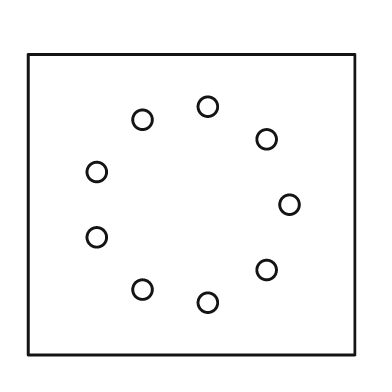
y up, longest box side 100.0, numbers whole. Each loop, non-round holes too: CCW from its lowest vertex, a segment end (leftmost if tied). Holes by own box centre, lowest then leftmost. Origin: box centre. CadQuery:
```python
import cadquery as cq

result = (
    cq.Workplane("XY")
    .moveTo(-50.0, -46.0)
    .lineTo(50.0, -46.0)
    .lineTo(50.0, 46.0)
    .lineTo(-50.0, 46.0)
    .close()
    .moveTo(5.0, -30.0)
    .circle(3.0)
    .moveTo(-15.0, -26.0)
    .circle(3.0)
    .moveTo(23.0, -20.0)
    .circle(3.0)
    .moveTo(-29.0, -10.0)
    .circle(3.0)
    .moveTo(30.0, 0.0)
    .circle(3.0)
    .moveTo(-29.0, 10.0)
    .circle(3.0)
    .moveTo(23.0, 20.0)
    .circle(3.0)
    .moveTo(-15.0, 26.0)
    .circle(3.0)
    .moveTo(5.0, 30.0)
    .circle(3.0)
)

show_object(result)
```